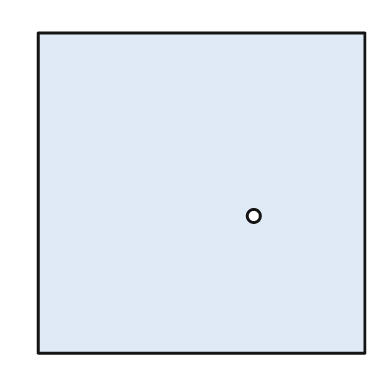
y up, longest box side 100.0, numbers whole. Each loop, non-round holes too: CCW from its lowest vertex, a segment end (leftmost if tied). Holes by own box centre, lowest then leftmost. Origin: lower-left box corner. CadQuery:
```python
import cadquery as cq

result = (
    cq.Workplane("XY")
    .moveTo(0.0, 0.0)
    .lineTo(100.0, 0.0)
    .lineTo(100.0, 98.0)
    .lineTo(0.0, 98.0)
    .close()
    .moveTo(66.0, 42.0)
    .circle(2.0)
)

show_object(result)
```